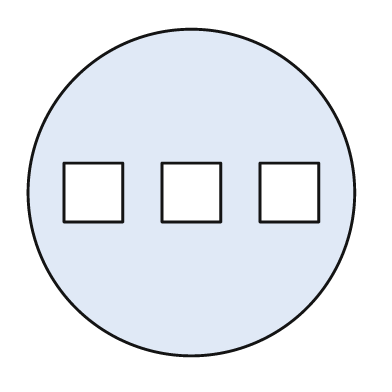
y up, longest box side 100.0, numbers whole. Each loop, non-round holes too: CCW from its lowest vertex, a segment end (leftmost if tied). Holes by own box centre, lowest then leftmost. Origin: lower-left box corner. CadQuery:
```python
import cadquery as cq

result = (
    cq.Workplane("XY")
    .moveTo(50.0, 50.0)
    .circle(50.0)
    .moveTo(11.0, 41.0)
    .lineTo(29.0, 41.0)
    .lineTo(29.0, 59.0)
    .lineTo(11.0, 59.0)
    .close()
    .moveTo(41.0, 41.0)
    .lineTo(59.0, 41.0)
    .lineTo(59.0, 59.0)
    .lineTo(41.0, 59.0)
    .close()
    .moveTo(71.0, 41.0)
    .lineTo(89.0, 41.0)
    .lineTo(89.0, 59.0)
    .lineTo(71.0, 59.0)
    .close()
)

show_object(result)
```